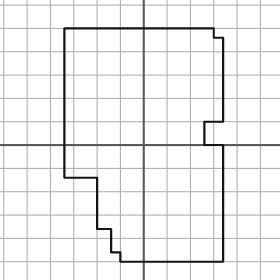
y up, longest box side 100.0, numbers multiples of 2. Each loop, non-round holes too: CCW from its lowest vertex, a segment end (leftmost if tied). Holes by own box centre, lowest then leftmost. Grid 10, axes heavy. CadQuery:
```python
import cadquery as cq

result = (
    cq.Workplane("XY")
    .moveTo(-10.0, -50.0)
    .lineTo(34.0, -50.0)
    .lineTo(34.0, 0.0)
    .lineTo(26.0, 0.0)
    .lineTo(26.0, 10.0)
    .lineTo(34.0, 10.0)
    .lineTo(34.0, 46.0)
    .lineTo(30.0, 46.0)
    .lineTo(30.0, 50.0)
    .lineTo(-34.0, 50.0)
    .lineTo(-34.0, -14.0)
    .lineTo(-20.0, -14.0)
    .lineTo(-20.0, -36.0)
    .lineTo(-14.0, -36.0)
    .lineTo(-14.0, -46.0)
    .lineTo(-10.0, -46.0)
    .close()
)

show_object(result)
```